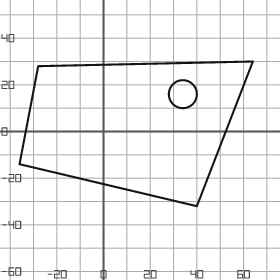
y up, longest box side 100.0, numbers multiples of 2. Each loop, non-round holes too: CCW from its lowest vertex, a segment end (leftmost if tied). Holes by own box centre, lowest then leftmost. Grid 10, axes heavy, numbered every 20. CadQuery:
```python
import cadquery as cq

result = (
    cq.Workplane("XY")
    .moveTo(40.0, -32.0)
    .lineTo(64.0, 30.0)
    .lineTo(-28.0, 28.0)
    .lineTo(-36.0, -14.0)
    .close()
    .moveTo(34.0, 16.0)
    .circle(6.0)
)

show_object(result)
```